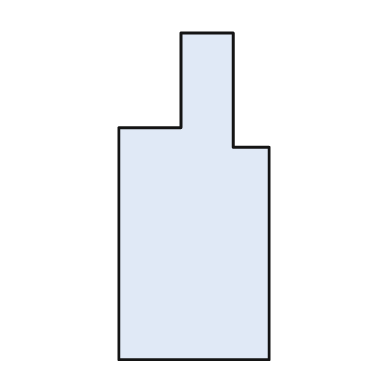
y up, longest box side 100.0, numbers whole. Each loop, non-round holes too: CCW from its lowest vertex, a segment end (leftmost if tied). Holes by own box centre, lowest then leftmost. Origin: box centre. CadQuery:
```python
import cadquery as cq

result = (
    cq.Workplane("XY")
    .moveTo(-23.0, -50.0)
    .lineTo(23.0, -50.0)
    .lineTo(23.0, 15.0)
    .lineTo(12.0, 15.0)
    .lineTo(12.0, 50.0)
    .lineTo(-4.0, 50.0)
    .lineTo(-4.0, 21.0)
    .lineTo(-23.0, 21.0)
    .close()
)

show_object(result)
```